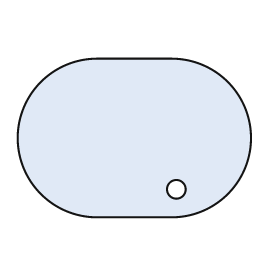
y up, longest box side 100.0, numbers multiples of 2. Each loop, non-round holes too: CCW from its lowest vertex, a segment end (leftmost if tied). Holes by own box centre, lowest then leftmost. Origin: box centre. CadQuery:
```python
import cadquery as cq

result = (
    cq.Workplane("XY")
    .moveTo(-16.0, -34.0)
    .lineTo(16.0, -34.0)
    .threePointArc((50.0, 0.0), (16.0, 34.0))
    .lineTo(-16.0, 34.0)
    .threePointArc((-50.0, 0.0), (-16.0, -34.0))
    .close()
    .moveTo(18.0, -22.0)
    .circle(4.0)
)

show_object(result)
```